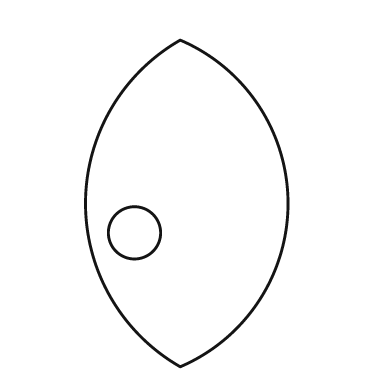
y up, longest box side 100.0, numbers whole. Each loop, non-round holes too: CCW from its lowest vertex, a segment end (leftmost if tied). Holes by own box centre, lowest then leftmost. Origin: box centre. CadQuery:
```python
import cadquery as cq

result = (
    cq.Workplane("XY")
    .moveTo(-2.0, -50.0)
    .threePointArc((31.0, 0.0), (-2.0, 50.0))
    .threePointArc((-31.0, 0.0), (-2.0, -50.0))
    .close()
    .moveTo(-16.0, -9.0)
    .circle(8.0)
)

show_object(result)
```